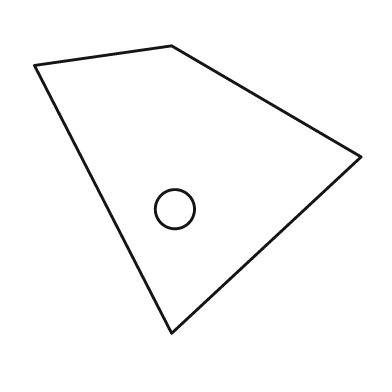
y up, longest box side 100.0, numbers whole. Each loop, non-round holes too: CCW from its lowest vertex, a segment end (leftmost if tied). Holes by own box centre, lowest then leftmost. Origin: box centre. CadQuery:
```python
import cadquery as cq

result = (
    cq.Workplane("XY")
    .moveTo(-8.0, -44.0)
    .lineTo(50.0, 10.0)
    .lineTo(-8.0, 44.0)
    .lineTo(-50.0, 38.0)
    .close()
    .moveTo(-7.0, -6.0)
    .circle(6.0)
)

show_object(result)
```